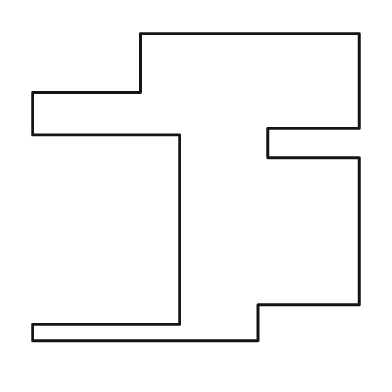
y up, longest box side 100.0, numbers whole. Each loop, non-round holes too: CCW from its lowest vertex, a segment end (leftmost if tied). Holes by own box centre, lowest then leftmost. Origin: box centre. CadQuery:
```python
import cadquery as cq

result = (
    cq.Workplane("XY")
    .moveTo(-50.0, -47.0)
    .lineTo(19.0, -47.0)
    .lineTo(19.0, -36.0)
    .lineTo(50.0, -36.0)
    .lineTo(50.0, 9.0)
    .lineTo(22.0, 9.0)
    .lineTo(22.0, 18.0)
    .lineTo(50.0, 18.0)
    .lineTo(50.0, 47.0)
    .lineTo(-17.0, 47.0)
    .lineTo(-17.0, 29.0)
    .lineTo(-50.0, 29.0)
    .lineTo(-50.0, 16.0)
    .lineTo(-5.0, 16.0)
    .lineTo(-5.0, -42.0)
    .lineTo(-50.0, -42.0)
    .close()
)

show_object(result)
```